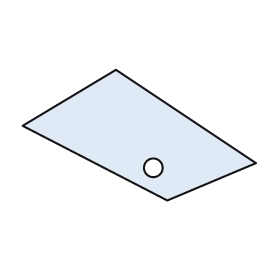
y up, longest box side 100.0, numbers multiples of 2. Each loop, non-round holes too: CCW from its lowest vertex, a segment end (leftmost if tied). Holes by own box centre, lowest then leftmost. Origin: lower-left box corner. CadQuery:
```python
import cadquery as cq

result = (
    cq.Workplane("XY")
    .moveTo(62.0, 0.0)
    .lineTo(100.0, 16.0)
    .lineTo(40.0, 56.0)
    .lineTo(0.0, 32.0)
    .close()
    .moveTo(56.0, 14.0)
    .circle(4.0)
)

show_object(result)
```